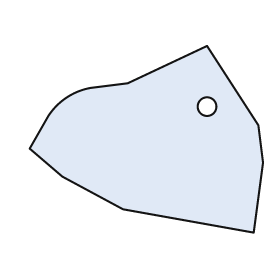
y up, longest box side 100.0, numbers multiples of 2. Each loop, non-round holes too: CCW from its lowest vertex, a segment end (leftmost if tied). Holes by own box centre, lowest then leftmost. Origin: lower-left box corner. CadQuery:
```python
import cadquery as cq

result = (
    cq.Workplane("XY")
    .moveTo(96.0, 0.0)
    .lineTo(100.0, 30.0)
    .lineTo(98.0, 46.0)
    .lineTo(76.0, 80.0)
    .lineTo(42.0, 64.0)
    .lineTo(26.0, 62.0)
    .threePointArc((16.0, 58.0), (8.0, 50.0))
    .lineTo(0.0, 36.0)
    .lineTo(14.0, 24.0)
    .lineTo(40.0, 10.0)
    .close()
    .moveTo(76.0, 54.0)
    .circle(4.0)
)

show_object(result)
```